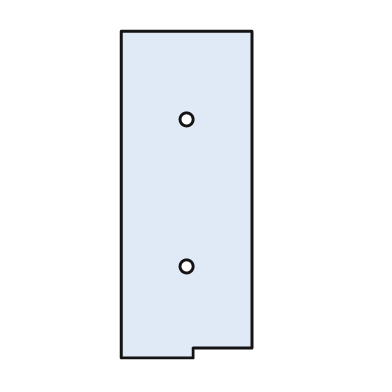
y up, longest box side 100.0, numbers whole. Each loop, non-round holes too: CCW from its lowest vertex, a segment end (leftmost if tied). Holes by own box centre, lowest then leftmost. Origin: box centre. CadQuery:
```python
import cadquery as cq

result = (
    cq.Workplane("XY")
    .moveTo(-20.0, -50.0)
    .lineTo(2.0, -50.0)
    .lineTo(2.0, -47.0)
    .lineTo(20.0, -47.0)
    .lineTo(20.0, 50.0)
    .lineTo(-20.0, 50.0)
    .close()
    .moveTo(0.0, -22.0)
    .circle(2.0)
    .moveTo(0.0, 23.0)
    .circle(2.0)
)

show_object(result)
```